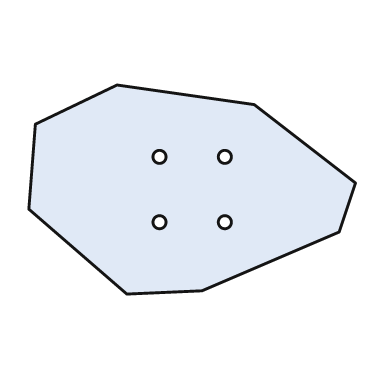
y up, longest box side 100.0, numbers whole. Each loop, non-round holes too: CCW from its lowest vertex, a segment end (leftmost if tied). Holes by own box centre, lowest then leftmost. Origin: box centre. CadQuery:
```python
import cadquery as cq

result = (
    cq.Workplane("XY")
    .moveTo(-20.0, -32.0)
    .lineTo(3.0, -31.0)
    .lineTo(45.0, -13.0)
    .lineTo(50.0, 2.0)
    .lineTo(19.0, 26.0)
    .lineTo(-23.0, 32.0)
    .lineTo(-48.0, 20.0)
    .lineTo(-50.0, -6.0)
    .close()
    .moveTo(-10.0, -10.0)
    .circle(2.0)
    .moveTo(10.0, -10.0)
    .circle(2.0)
    .moveTo(-10.0, 10.0)
    .circle(2.0)
    .moveTo(10.0, 10.0)
    .circle(2.0)
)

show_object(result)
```